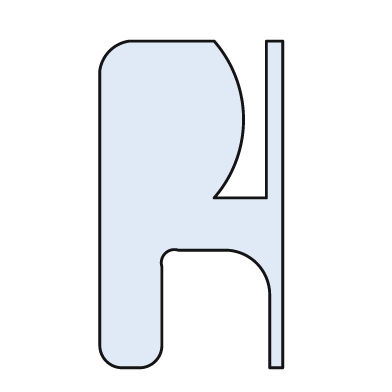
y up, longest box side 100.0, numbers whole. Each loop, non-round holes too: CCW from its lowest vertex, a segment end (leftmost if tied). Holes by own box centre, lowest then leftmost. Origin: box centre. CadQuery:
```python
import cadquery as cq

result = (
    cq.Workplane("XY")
    .moveTo(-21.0, -50.0)
    .lineTo(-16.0, -50.0)
    .threePointArc((-11.0, -48.0), (-9.0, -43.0))
    .lineTo(-9.0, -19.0)
    .threePointArc((-8.0, -15.0), (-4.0, -14.0))
    .lineTo(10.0, -14.0)
    .threePointArc((20.0, -18.0), (24.0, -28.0))
    .lineTo(24.0, -50.0)
    .lineTo(28.0, -50.0)
    .lineTo(28.0, 50.0)
    .lineTo(23.0, 50.0)
    .lineTo(23.0, 2.0)
    .lineTo(7.0, 2.0)
    .threePointArc((16.0, 26.0), (7.0, 50.0))
    .lineTo(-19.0, 50.0)
    .threePointArc((-25.0, 47.0), (-28.0, 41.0))
    .lineTo(-28.0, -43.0)
    .threePointArc((-26.0, -48.0), (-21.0, -50.0))
    .close()
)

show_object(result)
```